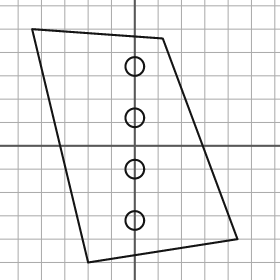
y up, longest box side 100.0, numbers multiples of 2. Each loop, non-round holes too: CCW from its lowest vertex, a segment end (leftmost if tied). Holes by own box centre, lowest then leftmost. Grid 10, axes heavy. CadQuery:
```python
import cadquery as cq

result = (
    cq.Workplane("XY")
    .moveTo(-20.0, -50.0)
    .lineTo(44.0, -40.0)
    .lineTo(12.0, 46.0)
    .lineTo(-44.0, 50.0)
    .close()
    .moveTo(0.0, -32.0)
    .circle(4.0)
    .moveTo(0.0, -10.0)
    .circle(4.0)
    .moveTo(0.0, 12.0)
    .circle(4.0)
    .moveTo(0.0, 34.0)
    .circle(4.0)
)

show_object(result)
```